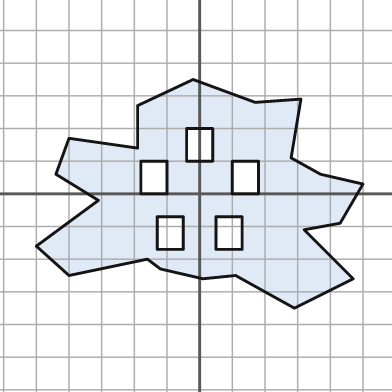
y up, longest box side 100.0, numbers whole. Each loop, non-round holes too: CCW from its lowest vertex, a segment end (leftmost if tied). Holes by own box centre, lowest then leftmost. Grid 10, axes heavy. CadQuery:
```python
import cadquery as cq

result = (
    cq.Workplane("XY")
    .moveTo(29.0, -35.0)
    .lineTo(47.0, -26.0)
    .lineTo(32.0, -11.0)
    .lineTo(43.0, -9.0)
    .lineTo(50.0, 3.0)
    .lineTo(37.0, 6.0)
    .lineTo(28.0, 11.0)
    .lineTo(31.0, 29.0)
    .lineTo(17.0, 28.0)
    .lineTo(-2.0, 35.0)
    .lineTo(-19.0, 27.0)
    .lineTo(-19.0, 14.0)
    .lineTo(-40.0, 17.0)
    .lineTo(-44.0, 6.0)
    .lineTo(-31.0, -2.0)
    .lineTo(-50.0, -16.0)
    .lineTo(-40.0, -25.0)
    .lineTo(-16.0, -20.0)
    .lineTo(-12.0, -23.0)
    .lineTo(1.0, -26.0)
    .lineTo(11.0, -25.0)
    .close()
    .moveTo(-13.0, -17.0)
    .lineTo(-5.0, -17.0)
    .lineTo(-5.0, -7.0)
    .lineTo(-13.0, -7.0)
    .close()
    .moveTo(5.0, -17.0)
    .lineTo(13.0, -17.0)
    .lineTo(13.0, -7.0)
    .lineTo(5.0, -7.0)
    .close()
    .moveTo(-18.0, 0.0)
    .lineTo(-10.0, 0.0)
    .lineTo(-10.0, 10.0)
    .lineTo(-18.0, 10.0)
    .close()
    .moveTo(10.0, 0.0)
    .lineTo(18.0, 0.0)
    .lineTo(18.0, 10.0)
    .lineTo(10.0, 10.0)
    .close()
    .moveTo(-4.0, 10.0)
    .lineTo(4.0, 10.0)
    .lineTo(4.0, 20.0)
    .lineTo(-4.0, 20.0)
    .close()
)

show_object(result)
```